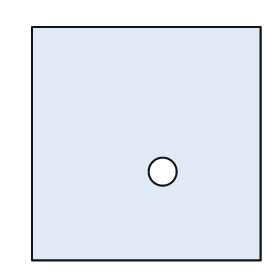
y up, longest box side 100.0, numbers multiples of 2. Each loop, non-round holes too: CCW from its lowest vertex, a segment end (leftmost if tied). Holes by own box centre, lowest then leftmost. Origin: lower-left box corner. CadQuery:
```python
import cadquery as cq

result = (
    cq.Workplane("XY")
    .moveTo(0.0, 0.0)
    .lineTo(98.0, 0.0)
    .lineTo(98.0, 100.0)
    .lineTo(0.0, 100.0)
    .close()
    .moveTo(56.0, 38.0)
    .circle(6.0)
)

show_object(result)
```